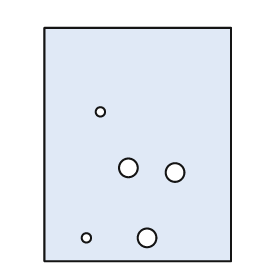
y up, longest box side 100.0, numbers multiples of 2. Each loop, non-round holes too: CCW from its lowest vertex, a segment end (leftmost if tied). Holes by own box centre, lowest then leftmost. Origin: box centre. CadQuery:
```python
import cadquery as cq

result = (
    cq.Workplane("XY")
    .moveTo(-40.0, -50.0)
    .lineTo(40.0, -50.0)
    .lineTo(40.0, 50.0)
    .lineTo(-40.0, 50.0)
    .close()
    .moveTo(-22.0, -40.0)
    .circle(2.0)
    .moveTo(4.0, -40.0)
    .circle(4.0)
    .moveTo(16.0, -12.0)
    .circle(4.0)
    .moveTo(-4.0, -10.0)
    .circle(4.0)
    .moveTo(-16.0, 14.0)
    .circle(2.0)
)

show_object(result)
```